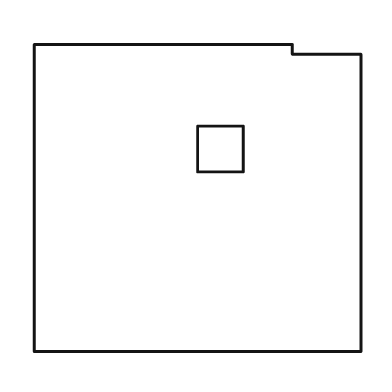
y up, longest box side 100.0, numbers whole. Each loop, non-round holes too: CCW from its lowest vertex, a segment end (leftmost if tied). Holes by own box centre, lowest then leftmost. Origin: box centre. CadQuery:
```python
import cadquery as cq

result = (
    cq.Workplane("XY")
    .moveTo(-50.0, -47.0)
    .lineTo(50.0, -47.0)
    .lineTo(50.0, 44.0)
    .lineTo(29.0, 44.0)
    .lineTo(29.0, 47.0)
    .lineTo(-50.0, 47.0)
    .close()
    .moveTo(0.0, 8.0)
    .lineTo(14.0, 8.0)
    .lineTo(14.0, 22.0)
    .lineTo(0.0, 22.0)
    .close()
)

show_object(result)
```